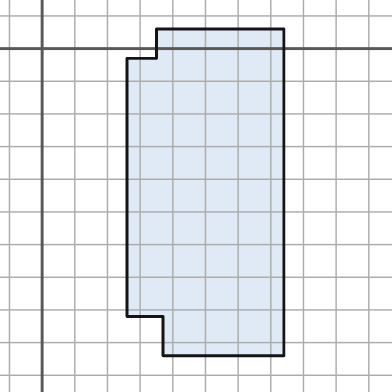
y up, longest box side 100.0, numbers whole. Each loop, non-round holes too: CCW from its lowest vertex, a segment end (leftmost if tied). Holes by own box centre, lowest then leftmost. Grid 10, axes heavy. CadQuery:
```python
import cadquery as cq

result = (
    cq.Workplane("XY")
    .moveTo(37.0, -94.0)
    .lineTo(74.0, -94.0)
    .lineTo(74.0, 6.0)
    .lineTo(35.0, 6.0)
    .lineTo(35.0, -3.0)
    .lineTo(26.0, -3.0)
    .lineTo(26.0, -82.0)
    .lineTo(37.0, -82.0)
    .close()
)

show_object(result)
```